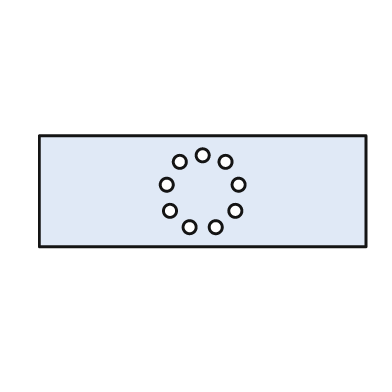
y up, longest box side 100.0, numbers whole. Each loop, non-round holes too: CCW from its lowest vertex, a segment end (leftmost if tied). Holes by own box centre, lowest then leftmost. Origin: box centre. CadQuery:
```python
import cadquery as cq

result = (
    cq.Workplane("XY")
    .moveTo(-50.0, -17.0)
    .lineTo(50.0, -17.0)
    .lineTo(50.0, 17.0)
    .lineTo(-50.0, 17.0)
    .close()
    .moveTo(-4.0, -11.0)
    .circle(2.0)
    .moveTo(4.0, -11.0)
    .circle(2.0)
    .moveTo(-10.0, -6.0)
    .circle(2.0)
    .moveTo(10.0, -6.0)
    .circle(2.0)
    .moveTo(-11.0, 2.0)
    .circle(2.0)
    .moveTo(11.0, 2.0)
    .circle(2.0)
    .moveTo(-7.0, 9.0)
    .circle(2.0)
    .moveTo(7.0, 9.0)
    .circle(2.0)
    .moveTo(0.0, 11.0)
    .circle(2.0)
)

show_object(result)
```